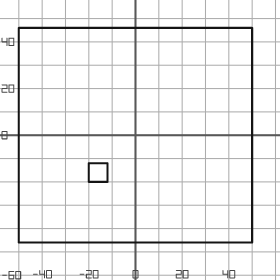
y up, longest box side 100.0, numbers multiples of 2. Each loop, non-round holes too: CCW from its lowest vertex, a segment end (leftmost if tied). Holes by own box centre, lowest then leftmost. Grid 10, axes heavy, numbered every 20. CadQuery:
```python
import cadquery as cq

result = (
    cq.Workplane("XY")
    .moveTo(-50.0, -46.0)
    .lineTo(50.0, -46.0)
    .lineTo(50.0, 46.0)
    .lineTo(-50.0, 46.0)
    .close()
    .moveTo(-20.0, -20.0)
    .lineTo(-12.0, -20.0)
    .lineTo(-12.0, -12.0)
    .lineTo(-20.0, -12.0)
    .close()
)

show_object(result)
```